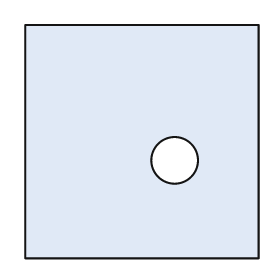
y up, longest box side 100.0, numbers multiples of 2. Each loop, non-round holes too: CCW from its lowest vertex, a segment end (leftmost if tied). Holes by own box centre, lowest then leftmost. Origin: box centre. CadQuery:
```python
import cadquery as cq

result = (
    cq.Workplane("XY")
    .moveTo(-50.0, -50.0)
    .lineTo(50.0, -50.0)
    .lineTo(50.0, 50.0)
    .lineTo(-50.0, 50.0)
    .close()
    .moveTo(14.0, -8.0)
    .circle(10.0)
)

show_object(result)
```